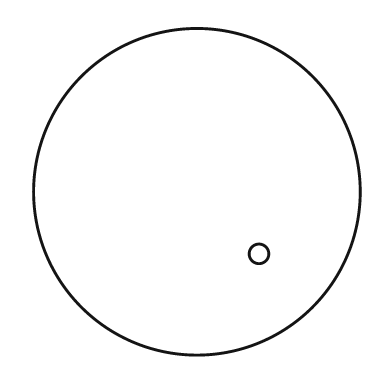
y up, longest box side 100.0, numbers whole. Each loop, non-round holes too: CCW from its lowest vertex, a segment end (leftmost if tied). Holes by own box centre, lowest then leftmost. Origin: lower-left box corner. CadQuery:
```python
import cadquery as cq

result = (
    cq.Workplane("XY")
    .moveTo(50.0, 50.0)
    .circle(50.0)
    .moveTo(69.0, 31.0)
    .circle(3.0)
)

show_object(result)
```